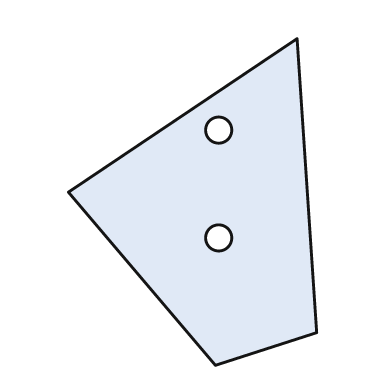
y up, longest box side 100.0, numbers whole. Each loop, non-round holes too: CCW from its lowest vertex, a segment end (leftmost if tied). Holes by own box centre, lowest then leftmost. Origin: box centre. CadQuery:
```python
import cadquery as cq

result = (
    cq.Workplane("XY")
    .moveTo(7.0, -50.0)
    .lineTo(38.0, -40.0)
    .lineTo(32.0, 50.0)
    .lineTo(-38.0, 3.0)
    .close()
    .moveTo(8.0, -11.0)
    .circle(4.0)
    .moveTo(8.0, 22.0)
    .circle(4.0)
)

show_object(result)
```